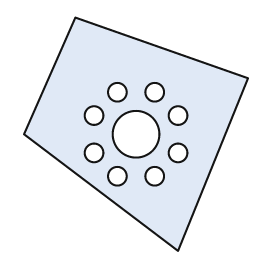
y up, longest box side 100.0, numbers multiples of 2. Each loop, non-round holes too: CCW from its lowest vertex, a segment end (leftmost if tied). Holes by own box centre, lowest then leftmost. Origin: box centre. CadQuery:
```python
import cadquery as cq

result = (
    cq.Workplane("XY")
    .moveTo(18.0, -50.0)
    .lineTo(48.0, 24.0)
    .lineTo(-26.0, 50.0)
    .lineTo(-48.0, 0.0)
    .close()
    .moveTo(-8.0, -18.0)
    .circle(4.0)
    .moveTo(8.0, -18.0)
    .circle(4.0)
    .moveTo(-18.0, -8.0)
    .circle(4.0)
    .moveTo(18.0, -8.0)
    .circle(4.0)
    .moveTo(0.0, 0.0)
    .circle(10.0)
    .moveTo(-18.0, 8.0)
    .circle(4.0)
    .moveTo(18.0, 8.0)
    .circle(4.0)
    .moveTo(-8.0, 18.0)
    .circle(4.0)
    .moveTo(8.0, 18.0)
    .circle(4.0)
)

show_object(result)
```